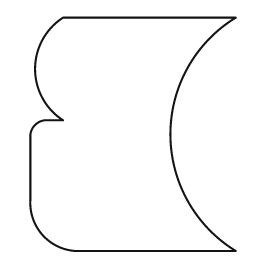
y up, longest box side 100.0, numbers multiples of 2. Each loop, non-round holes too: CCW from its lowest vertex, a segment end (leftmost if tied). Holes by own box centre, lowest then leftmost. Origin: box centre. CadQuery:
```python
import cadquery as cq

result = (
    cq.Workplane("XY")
    .moveTo(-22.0, -50.0)
    .lineTo(44.0, -50.0)
    .threePointArc((16.0, 0.0), (44.0, 50.0))
    .lineTo(-30.0, 50.0)
    .threePointArc((-42.0, 28.0), (-30.0, 6.0))
    .lineTo(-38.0, 6.0)
    .threePointArc((-42.0, 4.0), (-44.0, 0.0))
    .lineTo(-44.0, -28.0)
    .threePointArc((-38.0, -44.0), (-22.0, -50.0))
    .close()
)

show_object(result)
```